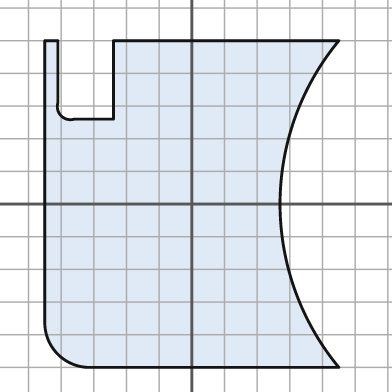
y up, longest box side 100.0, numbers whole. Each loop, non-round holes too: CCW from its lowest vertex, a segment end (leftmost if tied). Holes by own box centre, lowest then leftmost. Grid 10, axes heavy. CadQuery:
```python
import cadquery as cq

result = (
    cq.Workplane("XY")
    .moveTo(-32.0, -50.0)
    .lineTo(45.0, -50.0)
    .threePointArc((27.0, 0.0), (45.0, 50.0))
    .lineTo(-24.0, 50.0)
    .lineTo(-24.0, 26.0)
    .lineTo(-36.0, 26.0)
    .threePointArc((-40.0, 27.0), (-41.0, 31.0))
    .lineTo(-41.0, 50.0)
    .lineTo(-45.0, 50.0)
    .lineTo(-45.0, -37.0)
    .threePointArc((-41.0, -46.0), (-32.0, -50.0))
    .close()
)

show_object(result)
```